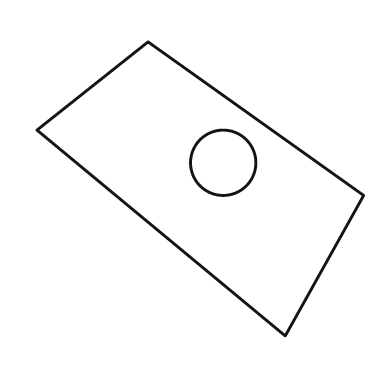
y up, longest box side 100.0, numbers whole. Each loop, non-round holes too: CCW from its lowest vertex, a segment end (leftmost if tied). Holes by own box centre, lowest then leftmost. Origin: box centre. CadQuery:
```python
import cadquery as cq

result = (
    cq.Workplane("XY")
    .moveTo(26.0, -45.0)
    .lineTo(50.0, -2.0)
    .lineTo(-16.0, 45.0)
    .lineTo(-50.0, 18.0)
    .close()
    .moveTo(7.0, 8.0)
    .circle(10.0)
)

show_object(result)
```